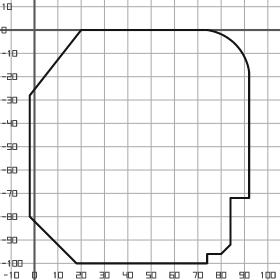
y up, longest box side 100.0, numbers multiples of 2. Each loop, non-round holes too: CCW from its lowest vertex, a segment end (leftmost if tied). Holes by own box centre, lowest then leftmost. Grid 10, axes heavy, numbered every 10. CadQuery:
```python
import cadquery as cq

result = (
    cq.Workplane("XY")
    .moveTo(18.0, -100.0)
    .lineTo(74.0, -100.0)
    .lineTo(74.0, -96.0)
    .lineTo(80.0, -96.0)
    .lineTo(84.0, -92.0)
    .lineTo(84.0, -72.0)
    .lineTo(92.0, -72.0)
    .lineTo(92.0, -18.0)
    .threePointArc((86.0, -6.0), (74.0, 0.0))
    .lineTo(20.0, 0.0)
    .lineTo(-2.0, -28.0)
    .lineTo(-2.0, -80.0)
    .close()
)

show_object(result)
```